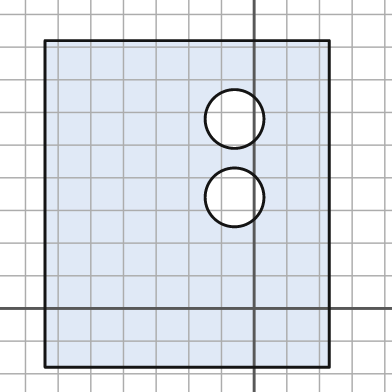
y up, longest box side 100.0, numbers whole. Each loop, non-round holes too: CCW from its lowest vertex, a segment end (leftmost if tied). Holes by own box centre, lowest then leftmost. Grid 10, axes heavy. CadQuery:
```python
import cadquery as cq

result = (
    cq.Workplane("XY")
    .moveTo(-64.0, -18.0)
    .lineTo(23.0, -18.0)
    .lineTo(23.0, 82.0)
    .lineTo(-64.0, 82.0)
    .close()
    .moveTo(-6.0, 34.0)
    .circle(9.0)
    .moveTo(-6.0, 58.0)
    .circle(9.0)
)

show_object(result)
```